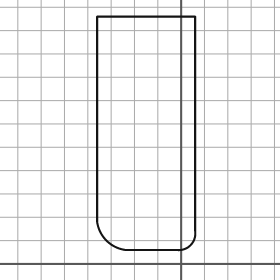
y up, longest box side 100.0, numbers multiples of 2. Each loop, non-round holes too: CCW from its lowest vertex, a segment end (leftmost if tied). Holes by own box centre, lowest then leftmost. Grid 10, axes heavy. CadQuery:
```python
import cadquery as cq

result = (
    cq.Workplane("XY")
    .moveTo(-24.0, 6.0)
    .lineTo(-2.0, 6.0)
    .threePointArc((4.0, 8.0), (6.0, 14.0))
    .lineTo(6.0, 106.0)
    .lineTo(-36.0, 106.0)
    .lineTo(-36.0, 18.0)
    .threePointArc((-32.0, 10.0), (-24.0, 6.0))
    .close()
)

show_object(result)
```